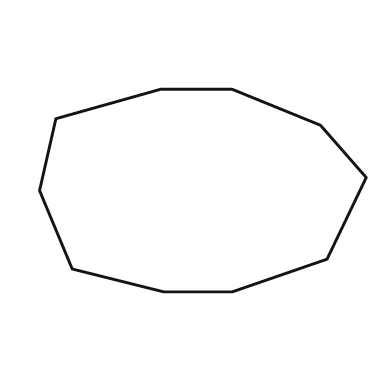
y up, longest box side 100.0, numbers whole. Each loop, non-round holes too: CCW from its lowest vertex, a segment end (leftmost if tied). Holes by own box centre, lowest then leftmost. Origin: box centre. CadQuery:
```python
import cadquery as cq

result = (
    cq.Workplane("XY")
    .moveTo(-12.0, -31.0)
    .lineTo(9.0, -31.0)
    .lineTo(38.0, -21.0)
    .lineTo(50.0, 4.0)
    .lineTo(36.0, 20.0)
    .lineTo(9.0, 31.0)
    .lineTo(-13.0, 31.0)
    .lineTo(-45.0, 22.0)
    .lineTo(-50.0, 0.0)
    .lineTo(-40.0, -24.0)
    .close()
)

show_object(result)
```